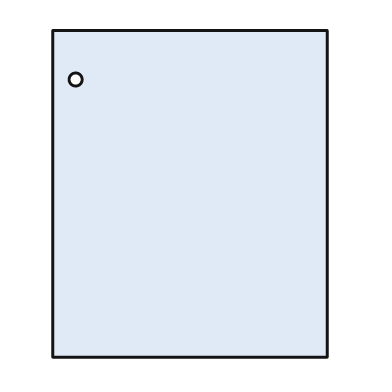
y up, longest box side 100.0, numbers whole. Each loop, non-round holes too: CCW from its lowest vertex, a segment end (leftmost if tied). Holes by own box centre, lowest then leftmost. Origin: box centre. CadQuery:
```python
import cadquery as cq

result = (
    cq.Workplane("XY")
    .moveTo(-42.0, -50.0)
    .lineTo(42.0, -50.0)
    .lineTo(42.0, 50.0)
    .lineTo(-42.0, 50.0)
    .close()
    .moveTo(-35.0, 35.0)
    .circle(2.0)
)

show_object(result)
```